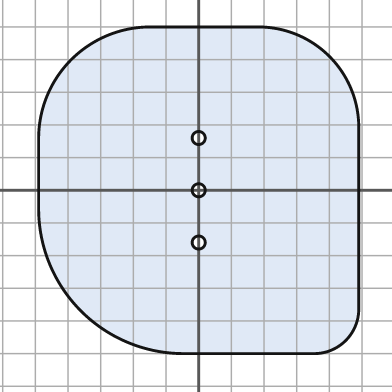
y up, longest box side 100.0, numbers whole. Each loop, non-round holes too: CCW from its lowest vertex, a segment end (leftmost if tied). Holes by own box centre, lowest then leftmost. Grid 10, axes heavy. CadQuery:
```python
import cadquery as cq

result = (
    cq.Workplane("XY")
    .moveTo(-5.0, -50.0)
    .lineTo(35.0, -50.0)
    .threePointArc((45.0, -46.0), (49.0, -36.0))
    .lineTo(49.0, 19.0)
    .threePointArc((40.0, 41.0), (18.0, 50.0))
    .lineTo(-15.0, 50.0)
    .threePointArc((-39.0, 40.0), (-49.0, 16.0))
    .lineTo(-49.0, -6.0)
    .threePointArc((-36.0, -37.0), (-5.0, -50.0))
    .close()
    .moveTo(0.0, -16.0)
    .circle(2.0)
    .moveTo(0.0, 0.0)
    .circle(2.0)
    .moveTo(0.0, 16.0)
    .circle(2.0)
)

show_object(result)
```